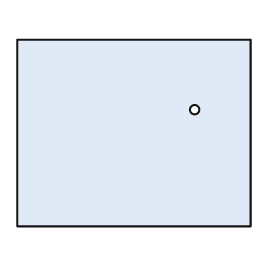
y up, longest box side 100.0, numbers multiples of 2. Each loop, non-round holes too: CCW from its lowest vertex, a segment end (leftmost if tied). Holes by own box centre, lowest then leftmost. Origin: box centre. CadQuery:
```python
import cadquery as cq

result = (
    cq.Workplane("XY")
    .moveTo(-50.0, -40.0)
    .lineTo(50.0, -40.0)
    .lineTo(50.0, 40.0)
    .lineTo(-50.0, 40.0)
    .close()
    .moveTo(26.0, 10.0)
    .circle(2.0)
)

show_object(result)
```